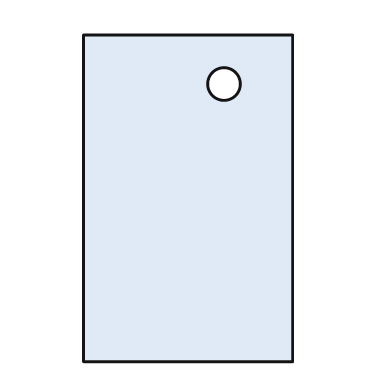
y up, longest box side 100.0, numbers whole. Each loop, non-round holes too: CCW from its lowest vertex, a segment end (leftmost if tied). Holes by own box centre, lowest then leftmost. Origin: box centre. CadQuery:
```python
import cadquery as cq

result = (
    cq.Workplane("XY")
    .moveTo(-32.0, -50.0)
    .lineTo(32.0, -50.0)
    .lineTo(32.0, 50.0)
    .lineTo(-32.0, 50.0)
    .close()
    .moveTo(11.0, 35.0)
    .circle(5.0)
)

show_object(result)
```